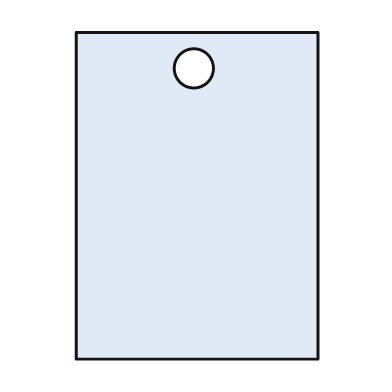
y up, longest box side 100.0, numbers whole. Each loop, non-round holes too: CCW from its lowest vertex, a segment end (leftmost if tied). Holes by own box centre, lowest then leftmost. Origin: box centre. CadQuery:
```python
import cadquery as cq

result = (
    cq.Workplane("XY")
    .moveTo(-37.0, -50.0)
    .lineTo(37.0, -50.0)
    .lineTo(37.0, 50.0)
    .lineTo(-37.0, 50.0)
    .close()
    .moveTo(-1.0, 39.0)
    .circle(6.0)
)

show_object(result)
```